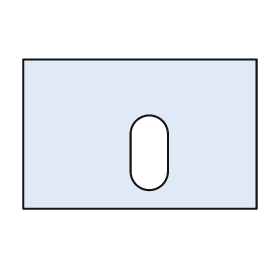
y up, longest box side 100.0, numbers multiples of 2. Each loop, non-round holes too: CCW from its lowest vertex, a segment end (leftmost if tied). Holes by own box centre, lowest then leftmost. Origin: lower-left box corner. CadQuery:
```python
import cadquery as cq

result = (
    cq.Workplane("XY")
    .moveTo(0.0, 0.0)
    .lineTo(100.0, 0.0)
    .lineTo(100.0, 64.0)
    .lineTo(0.0, 64.0)
    .close()
    .moveTo(46.0, 16.0)
    .threePointArc((54.0, 8.0), (62.0, 16.0))
    .lineTo(62.0, 32.0)
    .threePointArc((54.0, 40.0), (46.0, 32.0))
    .close()
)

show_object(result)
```